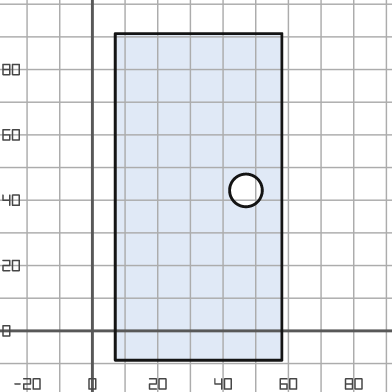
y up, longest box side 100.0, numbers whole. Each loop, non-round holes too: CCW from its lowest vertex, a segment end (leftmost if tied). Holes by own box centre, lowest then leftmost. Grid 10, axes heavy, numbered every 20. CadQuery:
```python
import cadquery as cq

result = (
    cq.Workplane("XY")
    .moveTo(7.0, -9.0)
    .lineTo(58.0, -9.0)
    .lineTo(58.0, 91.0)
    .lineTo(7.0, 91.0)
    .close()
    .moveTo(47.0, 43.0)
    .circle(5.0)
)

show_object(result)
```